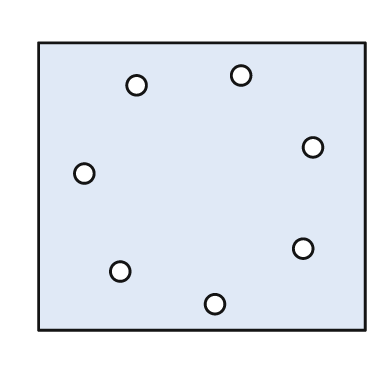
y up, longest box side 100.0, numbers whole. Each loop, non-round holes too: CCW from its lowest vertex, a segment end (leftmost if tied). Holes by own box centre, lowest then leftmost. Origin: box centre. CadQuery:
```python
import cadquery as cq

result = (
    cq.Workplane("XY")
    .moveTo(-50.0, -44.0)
    .lineTo(50.0, -44.0)
    .lineTo(50.0, 44.0)
    .lineTo(-50.0, 44.0)
    .close()
    .moveTo(4.0, -36.0)
    .circle(3.0)
    .moveTo(-25.0, -26.0)
    .circle(3.0)
    .moveTo(31.0, -19.0)
    .circle(3.0)
    .moveTo(-36.0, 4.0)
    .circle(3.0)
    .moveTo(34.0, 12.0)
    .circle(3.0)
    .moveTo(-20.0, 31.0)
    .circle(3.0)
    .moveTo(12.0, 34.0)
    .circle(3.0)
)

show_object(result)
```